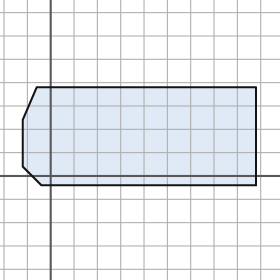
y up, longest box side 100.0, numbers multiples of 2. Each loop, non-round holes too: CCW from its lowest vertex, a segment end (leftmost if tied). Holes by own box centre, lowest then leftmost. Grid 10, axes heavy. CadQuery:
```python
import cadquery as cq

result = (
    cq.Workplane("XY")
    .moveTo(-4.0, -4.0)
    .lineTo(88.0, -4.0)
    .lineTo(88.0, 38.0)
    .lineTo(-6.0, 38.0)
    .lineTo(-12.0, 24.0)
    .lineTo(-12.0, 4.0)
    .close()
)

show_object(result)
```